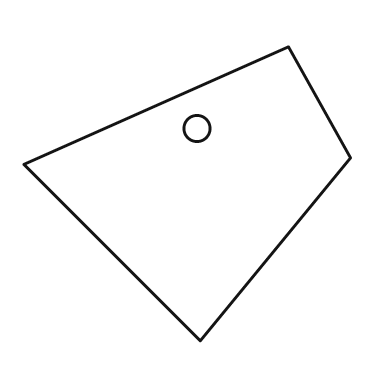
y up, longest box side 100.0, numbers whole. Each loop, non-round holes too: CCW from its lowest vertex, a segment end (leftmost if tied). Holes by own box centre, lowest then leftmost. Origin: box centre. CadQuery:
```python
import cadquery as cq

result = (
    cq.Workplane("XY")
    .moveTo(4.0, -45.0)
    .lineTo(50.0, 11.0)
    .lineTo(31.0, 45.0)
    .lineTo(-50.0, 9.0)
    .close()
    .moveTo(3.0, 20.0)
    .circle(4.0)
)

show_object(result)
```